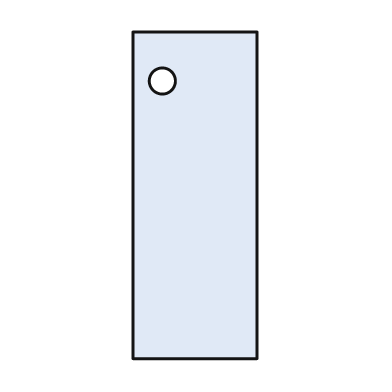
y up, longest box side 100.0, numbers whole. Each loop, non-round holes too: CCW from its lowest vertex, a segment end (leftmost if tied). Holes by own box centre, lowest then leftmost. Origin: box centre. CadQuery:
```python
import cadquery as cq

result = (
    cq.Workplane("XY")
    .moveTo(-19.0, -50.0)
    .lineTo(19.0, -50.0)
    .lineTo(19.0, 50.0)
    .lineTo(-19.0, 50.0)
    .close()
    .moveTo(-10.0, 35.0)
    .circle(4.0)
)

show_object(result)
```